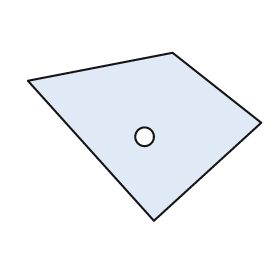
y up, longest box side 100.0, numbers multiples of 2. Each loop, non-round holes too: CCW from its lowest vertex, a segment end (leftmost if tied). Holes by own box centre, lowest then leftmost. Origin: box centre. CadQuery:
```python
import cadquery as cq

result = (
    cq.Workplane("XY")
    .moveTo(4.0, -36.0)
    .lineTo(50.0, 6.0)
    .lineTo(12.0, 36.0)
    .lineTo(-50.0, 24.0)
    .close()
    .moveTo(0.0, 0.0)
    .circle(4.0)
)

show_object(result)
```